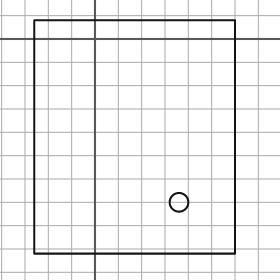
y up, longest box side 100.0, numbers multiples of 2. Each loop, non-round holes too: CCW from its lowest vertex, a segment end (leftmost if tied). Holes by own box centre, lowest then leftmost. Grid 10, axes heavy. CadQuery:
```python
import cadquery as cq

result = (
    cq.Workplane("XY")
    .moveTo(-26.0, -92.0)
    .lineTo(60.0, -92.0)
    .lineTo(60.0, 8.0)
    .lineTo(-26.0, 8.0)
    .close()
    .moveTo(36.0, -70.0)
    .circle(4.0)
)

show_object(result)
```